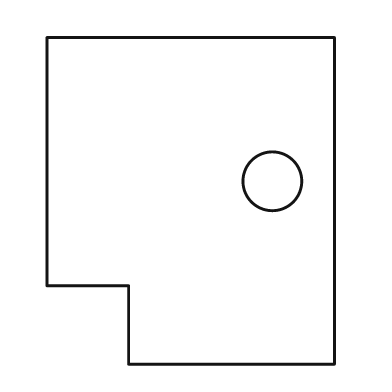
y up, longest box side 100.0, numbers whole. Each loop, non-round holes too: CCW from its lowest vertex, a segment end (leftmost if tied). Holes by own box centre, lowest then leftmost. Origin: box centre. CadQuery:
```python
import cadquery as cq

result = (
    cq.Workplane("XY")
    .moveTo(-19.0, -50.0)
    .lineTo(44.0, -50.0)
    .lineTo(44.0, 50.0)
    .lineTo(-44.0, 50.0)
    .lineTo(-44.0, -26.0)
    .lineTo(-19.0, -26.0)
    .close()
    .moveTo(25.0, 6.0)
    .circle(9.0)
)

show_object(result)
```